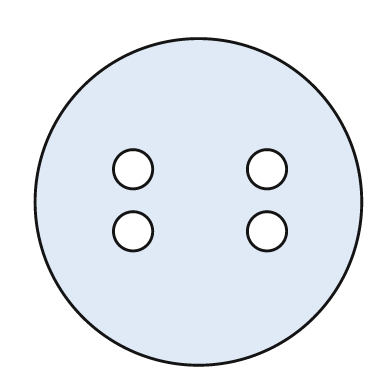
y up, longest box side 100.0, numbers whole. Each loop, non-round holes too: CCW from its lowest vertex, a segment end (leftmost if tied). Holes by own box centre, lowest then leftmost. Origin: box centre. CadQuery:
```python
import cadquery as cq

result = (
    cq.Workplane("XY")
    .moveTo(0.0, 0.0)
    .circle(50.0)
    .moveTo(-20.0, -9.0)
    .circle(6.0)
    .moveTo(21.0, -9.0)
    .circle(6.0)
    .moveTo(-20.0, 10.0)
    .circle(6.0)
    .moveTo(21.0, 10.0)
    .circle(6.0)
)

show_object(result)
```